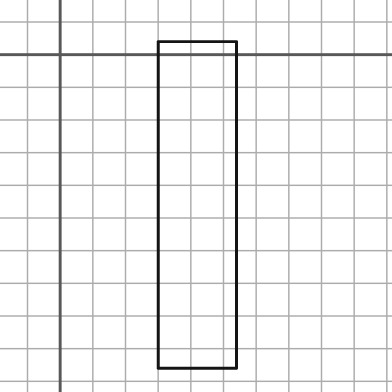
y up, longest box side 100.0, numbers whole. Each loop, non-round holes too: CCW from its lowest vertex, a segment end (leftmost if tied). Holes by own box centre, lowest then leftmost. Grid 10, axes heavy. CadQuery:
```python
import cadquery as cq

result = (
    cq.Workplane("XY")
    .moveTo(30.0, -96.0)
    .lineTo(54.0, -96.0)
    .lineTo(54.0, 4.0)
    .lineTo(30.0, 4.0)
    .close()
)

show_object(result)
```